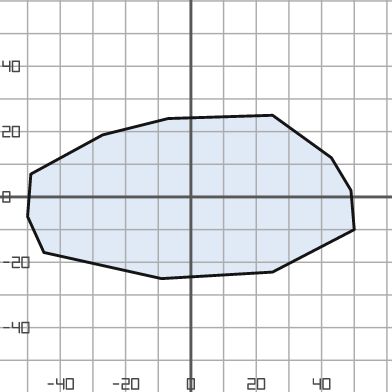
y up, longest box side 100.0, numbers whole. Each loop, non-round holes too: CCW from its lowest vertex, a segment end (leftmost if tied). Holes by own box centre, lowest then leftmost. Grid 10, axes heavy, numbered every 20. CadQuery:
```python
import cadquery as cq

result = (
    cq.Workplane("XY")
    .moveTo(-9.0, -25.0)
    .lineTo(25.0, -23.0)
    .lineTo(50.0, -10.0)
    .lineTo(49.0, 2.0)
    .lineTo(43.0, 12.0)
    .lineTo(25.0, 25.0)
    .lineTo(-7.0, 24.0)
    .lineTo(-27.0, 19.0)
    .lineTo(-49.0, 7.0)
    .lineTo(-50.0, -6.0)
    .lineTo(-45.0, -17.0)
    .close()
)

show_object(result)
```